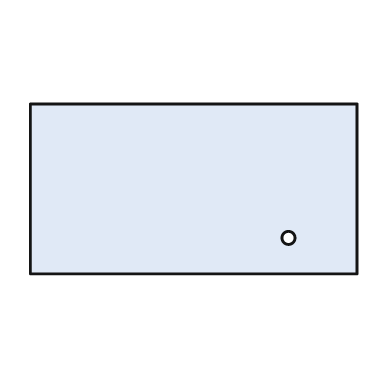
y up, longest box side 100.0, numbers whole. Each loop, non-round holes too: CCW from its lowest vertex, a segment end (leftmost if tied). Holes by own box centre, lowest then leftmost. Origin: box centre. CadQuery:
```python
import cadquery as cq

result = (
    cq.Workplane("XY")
    .moveTo(-50.0, -26.0)
    .lineTo(50.0, -26.0)
    .lineTo(50.0, 26.0)
    .lineTo(-50.0, 26.0)
    .close()
    .moveTo(29.0, -15.0)
    .circle(2.0)
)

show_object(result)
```